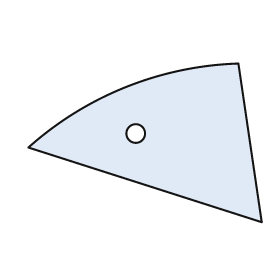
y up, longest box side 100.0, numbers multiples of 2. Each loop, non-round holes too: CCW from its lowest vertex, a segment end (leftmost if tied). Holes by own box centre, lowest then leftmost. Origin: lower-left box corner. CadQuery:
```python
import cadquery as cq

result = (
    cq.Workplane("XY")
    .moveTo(100.0, 0.0)
    .lineTo(90.0, 68.0)
    .threePointArc((42.0, 58.0), (0.0, 32.0))
    .close()
    .moveTo(46.0, 38.0)
    .circle(4.0)
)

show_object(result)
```